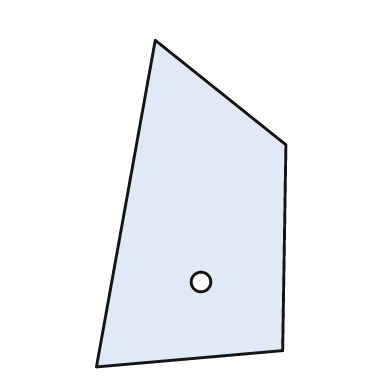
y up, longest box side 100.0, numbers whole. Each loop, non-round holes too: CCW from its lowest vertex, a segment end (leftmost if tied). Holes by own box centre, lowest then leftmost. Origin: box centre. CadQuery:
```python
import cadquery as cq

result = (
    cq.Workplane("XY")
    .moveTo(-29.0, -50.0)
    .lineTo(28.0, -45.0)
    .lineTo(29.0, 18.0)
    .lineTo(-11.0, 50.0)
    .close()
    .moveTo(3.0, -24.0)
    .circle(3.0)
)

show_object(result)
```